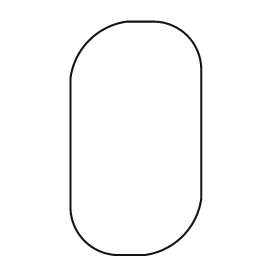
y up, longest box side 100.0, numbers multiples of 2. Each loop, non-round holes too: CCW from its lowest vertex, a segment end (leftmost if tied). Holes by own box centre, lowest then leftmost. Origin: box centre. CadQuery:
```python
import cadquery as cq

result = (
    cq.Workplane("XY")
    .moveTo(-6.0, -50.0)
    .lineTo(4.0, -50.0)
    .threePointArc((20.0, -42.0), (28.0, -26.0))
    .lineTo(28.0, 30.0)
    .threePointArc((22.0, 44.0), (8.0, 50.0))
    .lineTo(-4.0, 50.0)
    .threePointArc((-20.0, 42.0), (-28.0, 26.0))
    .lineTo(-28.0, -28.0)
    .threePointArc((-22.0, -44.0), (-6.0, -50.0))
    .close()
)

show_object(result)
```